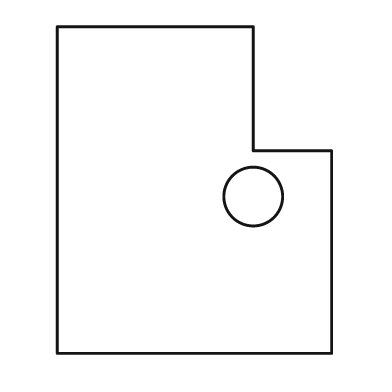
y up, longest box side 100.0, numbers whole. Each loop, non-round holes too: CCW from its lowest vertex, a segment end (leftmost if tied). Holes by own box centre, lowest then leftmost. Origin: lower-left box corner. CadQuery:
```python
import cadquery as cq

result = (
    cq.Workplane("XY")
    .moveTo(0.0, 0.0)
    .lineTo(84.0, 0.0)
    .lineTo(84.0, 62.0)
    .lineTo(60.0, 62.0)
    .lineTo(60.0, 100.0)
    .lineTo(0.0, 100.0)
    .close()
    .moveTo(60.0, 48.0)
    .circle(9.0)
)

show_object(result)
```